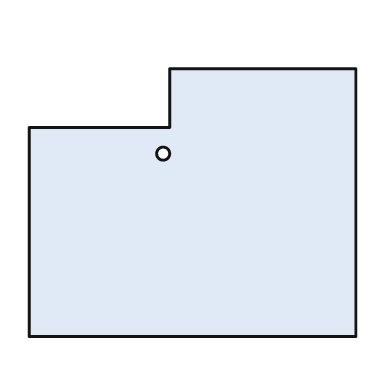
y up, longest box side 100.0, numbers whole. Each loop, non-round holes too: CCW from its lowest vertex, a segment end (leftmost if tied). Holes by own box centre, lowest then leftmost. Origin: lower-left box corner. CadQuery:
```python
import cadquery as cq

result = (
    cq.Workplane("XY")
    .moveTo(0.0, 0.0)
    .lineTo(100.0, 0.0)
    .lineTo(100.0, 82.0)
    .lineTo(43.0, 82.0)
    .lineTo(43.0, 64.0)
    .lineTo(0.0, 64.0)
    .close()
    .moveTo(41.0, 56.0)
    .circle(2.0)
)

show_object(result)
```